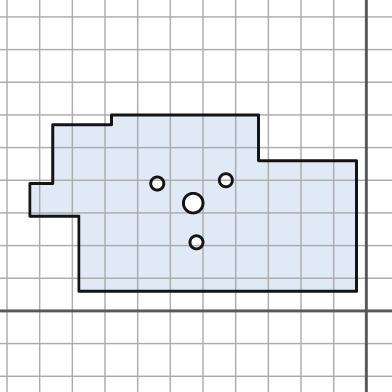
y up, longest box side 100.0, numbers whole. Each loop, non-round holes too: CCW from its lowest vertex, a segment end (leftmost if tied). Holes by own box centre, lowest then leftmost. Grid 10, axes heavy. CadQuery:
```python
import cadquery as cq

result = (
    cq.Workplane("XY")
    .moveTo(-88.0, 6.0)
    .lineTo(-3.0, 6.0)
    .lineTo(-3.0, 46.0)
    .lineTo(-33.0, 46.0)
    .lineTo(-33.0, 60.0)
    .lineTo(-78.0, 60.0)
    .lineTo(-78.0, 57.0)
    .lineTo(-96.0, 57.0)
    .lineTo(-96.0, 39.0)
    .lineTo(-103.0, 39.0)
    .lineTo(-103.0, 29.0)
    .lineTo(-88.0, 29.0)
    .close()
    .moveTo(-52.0, 21.0)
    .circle(2.0)
    .moveTo(-53.0, 33.0)
    .circle(3.0)
    .moveTo(-64.0, 39.0)
    .circle(2.0)
    .moveTo(-43.0, 40.0)
    .circle(2.0)
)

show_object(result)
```